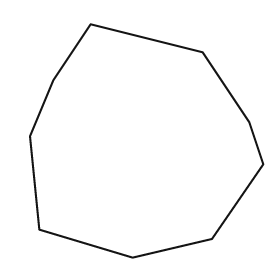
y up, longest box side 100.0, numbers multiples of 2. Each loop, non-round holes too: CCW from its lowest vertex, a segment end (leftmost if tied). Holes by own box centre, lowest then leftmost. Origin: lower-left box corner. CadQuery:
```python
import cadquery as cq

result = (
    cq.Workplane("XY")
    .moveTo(44.0, 0.0)
    .lineTo(78.0, 8.0)
    .lineTo(100.0, 40.0)
    .lineTo(94.0, 58.0)
    .lineTo(74.0, 88.0)
    .lineTo(26.0, 100.0)
    .lineTo(10.0, 76.0)
    .lineTo(0.0, 52.0)
    .lineTo(4.0, 12.0)
    .close()
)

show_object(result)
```